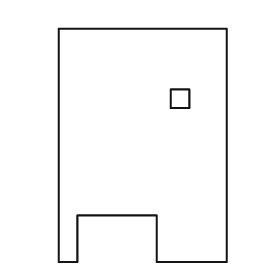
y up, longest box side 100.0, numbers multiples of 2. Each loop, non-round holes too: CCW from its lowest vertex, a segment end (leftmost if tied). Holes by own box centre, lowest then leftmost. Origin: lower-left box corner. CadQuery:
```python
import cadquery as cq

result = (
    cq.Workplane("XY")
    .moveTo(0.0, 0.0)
    .lineTo(8.0, 0.0)
    .lineTo(8.0, 20.0)
    .lineTo(42.0, 20.0)
    .lineTo(42.0, 0.0)
    .lineTo(72.0, 0.0)
    .lineTo(72.0, 100.0)
    .lineTo(0.0, 100.0)
    .close()
    .moveTo(48.0, 66.0)
    .lineTo(56.0, 66.0)
    .lineTo(56.0, 74.0)
    .lineTo(48.0, 74.0)
    .close()
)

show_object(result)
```